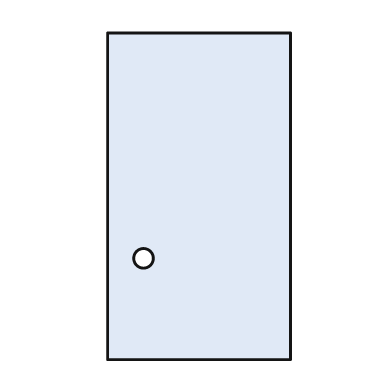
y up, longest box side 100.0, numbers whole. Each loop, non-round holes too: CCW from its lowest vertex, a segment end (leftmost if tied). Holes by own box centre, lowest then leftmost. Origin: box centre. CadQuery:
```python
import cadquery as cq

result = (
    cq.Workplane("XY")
    .moveTo(-28.0, -50.0)
    .lineTo(28.0, -50.0)
    .lineTo(28.0, 50.0)
    .lineTo(-28.0, 50.0)
    .close()
    .moveTo(-17.0, -19.0)
    .circle(3.0)
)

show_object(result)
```